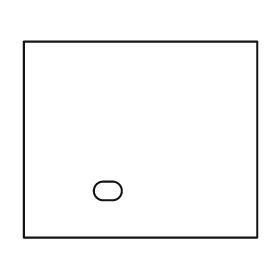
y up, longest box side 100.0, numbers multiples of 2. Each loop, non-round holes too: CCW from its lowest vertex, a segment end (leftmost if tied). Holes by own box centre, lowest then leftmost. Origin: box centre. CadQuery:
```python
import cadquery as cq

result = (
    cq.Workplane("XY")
    .moveTo(-50.0, -42.0)
    .lineTo(50.0, -42.0)
    .lineTo(50.0, 42.0)
    .lineTo(-50.0, 42.0)
    .close()
    .moveTo(-16.0, -26.0)
    .lineTo(-12.0, -26.0)
    .threePointArc((-8.0, -22.0), (-12.0, -18.0))
    .lineTo(-16.0, -18.0)
    .threePointArc((-20.0, -22.0), (-16.0, -26.0))
    .close()
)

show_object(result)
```